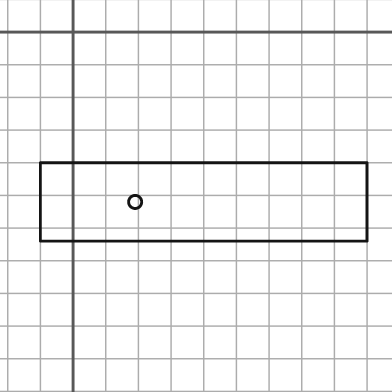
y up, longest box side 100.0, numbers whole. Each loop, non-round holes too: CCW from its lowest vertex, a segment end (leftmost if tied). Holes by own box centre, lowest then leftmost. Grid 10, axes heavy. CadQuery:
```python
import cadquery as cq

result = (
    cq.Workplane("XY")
    .moveTo(-10.0, -64.0)
    .lineTo(90.0, -64.0)
    .lineTo(90.0, -40.0)
    .lineTo(-10.0, -40.0)
    .close()
    .moveTo(19.0, -52.0)
    .circle(2.0)
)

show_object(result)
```